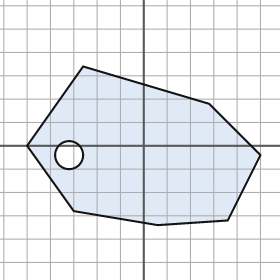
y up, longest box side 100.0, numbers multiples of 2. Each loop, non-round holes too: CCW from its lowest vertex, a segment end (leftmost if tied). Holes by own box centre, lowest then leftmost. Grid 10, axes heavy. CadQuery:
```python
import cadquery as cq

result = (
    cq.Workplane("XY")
    .moveTo(6.0, -34.0)
    .lineTo(36.0, -32.0)
    .lineTo(50.0, -4.0)
    .lineTo(28.0, 18.0)
    .lineTo(-26.0, 34.0)
    .lineTo(-50.0, 0.0)
    .lineTo(-30.0, -28.0)
    .close()
    .moveTo(-32.0, -4.0)
    .circle(6.0)
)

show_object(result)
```